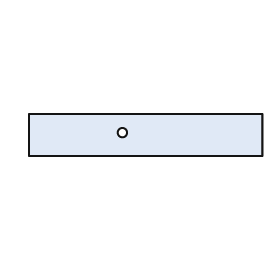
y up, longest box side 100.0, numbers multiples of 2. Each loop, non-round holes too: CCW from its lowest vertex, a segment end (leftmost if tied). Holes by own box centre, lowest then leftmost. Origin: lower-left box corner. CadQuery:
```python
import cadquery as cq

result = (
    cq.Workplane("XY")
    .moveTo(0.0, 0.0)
    .lineTo(100.0, 0.0)
    .lineTo(100.0, 18.0)
    .lineTo(0.0, 18.0)
    .close()
    .moveTo(40.0, 10.0)
    .circle(2.0)
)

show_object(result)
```